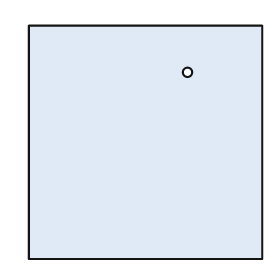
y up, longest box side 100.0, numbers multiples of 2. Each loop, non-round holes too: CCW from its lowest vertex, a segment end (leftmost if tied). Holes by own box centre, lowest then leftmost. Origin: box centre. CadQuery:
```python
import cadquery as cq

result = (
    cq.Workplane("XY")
    .moveTo(-50.0, -50.0)
    .lineTo(50.0, -50.0)
    .lineTo(50.0, 50.0)
    .lineTo(-50.0, 50.0)
    .close()
    .moveTo(18.0, 30.0)
    .circle(2.0)
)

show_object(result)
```